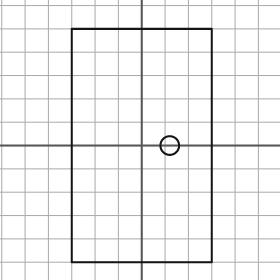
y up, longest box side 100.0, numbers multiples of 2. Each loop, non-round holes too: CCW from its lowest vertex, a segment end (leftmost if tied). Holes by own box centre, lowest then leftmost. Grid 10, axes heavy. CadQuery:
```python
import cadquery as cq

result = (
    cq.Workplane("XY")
    .moveTo(-30.0, -50.0)
    .lineTo(30.0, -50.0)
    .lineTo(30.0, 50.0)
    .lineTo(-30.0, 50.0)
    .close()
    .moveTo(12.0, 0.0)
    .circle(4.0)
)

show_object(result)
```